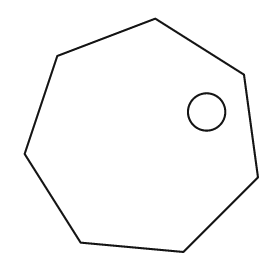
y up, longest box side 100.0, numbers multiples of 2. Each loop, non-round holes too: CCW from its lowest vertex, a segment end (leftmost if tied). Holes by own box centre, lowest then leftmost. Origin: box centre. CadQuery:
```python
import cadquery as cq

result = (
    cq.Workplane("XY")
    .moveTo(18.0, -50.0)
    .lineTo(50.0, -18.0)
    .lineTo(44.0, 26.0)
    .lineTo(6.0, 50.0)
    .lineTo(-36.0, 34.0)
    .lineTo(-50.0, -8.0)
    .lineTo(-26.0, -46.0)
    .close()
    .moveTo(28.0, 10.0)
    .circle(8.0)
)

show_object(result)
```